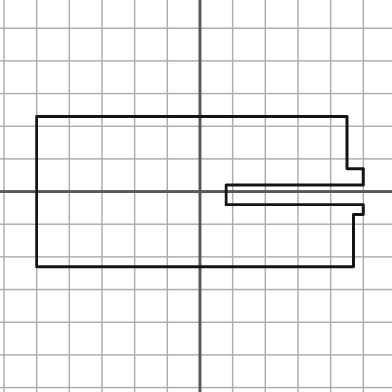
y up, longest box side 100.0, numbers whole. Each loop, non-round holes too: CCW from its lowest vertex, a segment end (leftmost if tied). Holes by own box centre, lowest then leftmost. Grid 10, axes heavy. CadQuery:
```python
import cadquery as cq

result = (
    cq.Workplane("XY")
    .moveTo(-50.0, -23.0)
    .lineTo(47.0, -23.0)
    .lineTo(47.0, -7.0)
    .lineTo(50.0, -7.0)
    .lineTo(50.0, -4.0)
    .lineTo(8.0, -4.0)
    .lineTo(8.0, 2.0)
    .lineTo(50.0, 2.0)
    .lineTo(50.0, 7.0)
    .lineTo(45.0, 7.0)
    .lineTo(45.0, 23.0)
    .lineTo(-50.0, 23.0)
    .close()
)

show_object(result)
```